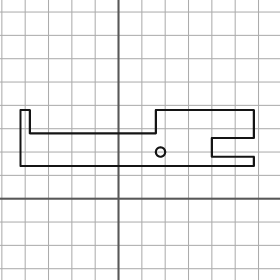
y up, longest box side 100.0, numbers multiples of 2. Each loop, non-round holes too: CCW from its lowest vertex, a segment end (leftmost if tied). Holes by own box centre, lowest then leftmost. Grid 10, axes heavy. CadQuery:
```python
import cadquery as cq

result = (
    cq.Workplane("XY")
    .moveTo(-42.0, 14.0)
    .lineTo(58.0, 14.0)
    .lineTo(58.0, 18.0)
    .lineTo(40.0, 18.0)
    .lineTo(40.0, 26.0)
    .lineTo(58.0, 26.0)
    .lineTo(58.0, 38.0)
    .lineTo(16.0, 38.0)
    .lineTo(16.0, 28.0)
    .lineTo(-38.0, 28.0)
    .lineTo(-38.0, 38.0)
    .lineTo(-42.0, 38.0)
    .close()
    .moveTo(18.0, 20.0)
    .circle(2.0)
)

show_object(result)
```